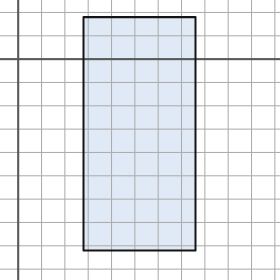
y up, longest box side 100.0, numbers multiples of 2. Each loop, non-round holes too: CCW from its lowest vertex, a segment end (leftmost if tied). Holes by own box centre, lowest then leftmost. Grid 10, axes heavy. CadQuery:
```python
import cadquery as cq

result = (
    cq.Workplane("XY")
    .moveTo(28.0, -82.0)
    .lineTo(76.0, -82.0)
    .lineTo(76.0, 18.0)
    .lineTo(28.0, 18.0)
    .close()
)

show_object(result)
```